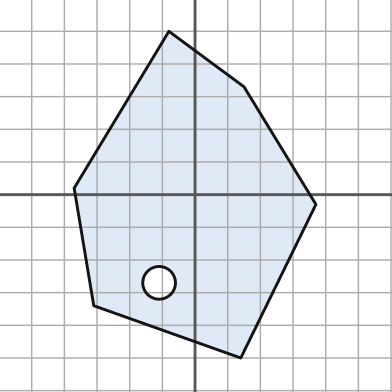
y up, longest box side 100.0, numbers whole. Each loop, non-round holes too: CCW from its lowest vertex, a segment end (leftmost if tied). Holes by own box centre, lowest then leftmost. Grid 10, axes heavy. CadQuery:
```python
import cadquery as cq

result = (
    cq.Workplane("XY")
    .moveTo(14.0, -50.0)
    .lineTo(37.0, -3.0)
    .lineTo(15.0, 33.0)
    .lineTo(-8.0, 50.0)
    .lineTo(-37.0, 2.0)
    .lineTo(-31.0, -34.0)
    .close()
    .moveTo(-11.0, -27.0)
    .circle(5.0)
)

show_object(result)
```